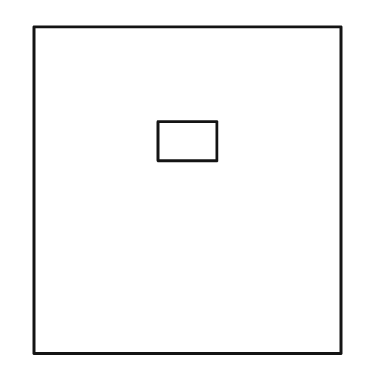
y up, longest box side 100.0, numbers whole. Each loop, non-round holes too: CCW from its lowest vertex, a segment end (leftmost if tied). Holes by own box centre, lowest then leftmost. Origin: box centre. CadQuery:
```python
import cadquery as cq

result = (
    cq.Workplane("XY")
    .moveTo(-47.0, -50.0)
    .lineTo(47.0, -50.0)
    .lineTo(47.0, 50.0)
    .lineTo(-47.0, 50.0)
    .close()
    .moveTo(-9.0, 9.0)
    .lineTo(9.0, 9.0)
    .lineTo(9.0, 21.0)
    .lineTo(-9.0, 21.0)
    .close()
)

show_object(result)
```